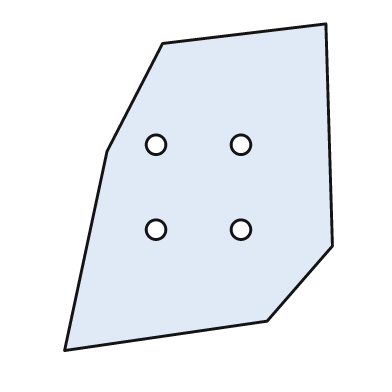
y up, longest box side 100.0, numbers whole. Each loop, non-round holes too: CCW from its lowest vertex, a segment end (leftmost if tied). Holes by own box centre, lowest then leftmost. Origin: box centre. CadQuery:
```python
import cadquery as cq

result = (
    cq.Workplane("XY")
    .moveTo(-41.0, -50.0)
    .lineTo(21.0, -41.0)
    .lineTo(41.0, -18.0)
    .lineTo(39.0, 50.0)
    .lineTo(-11.0, 44.0)
    .lineTo(-28.0, 11.0)
    .close()
    .moveTo(-13.0, -13.0)
    .circle(3.0)
    .moveTo(13.0, -13.0)
    .circle(3.0)
    .moveTo(-13.0, 13.0)
    .circle(3.0)
    .moveTo(13.0, 13.0)
    .circle(3.0)
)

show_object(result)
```